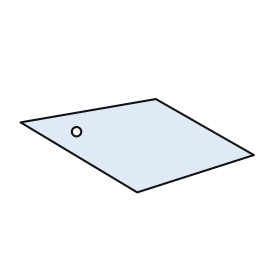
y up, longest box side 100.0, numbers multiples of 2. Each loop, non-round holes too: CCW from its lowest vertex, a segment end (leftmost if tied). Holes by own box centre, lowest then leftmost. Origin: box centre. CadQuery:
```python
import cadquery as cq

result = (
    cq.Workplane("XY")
    .moveTo(0.0, -20.0)
    .lineTo(50.0, -4.0)
    .lineTo(8.0, 20.0)
    .lineTo(-50.0, 10.0)
    .close()
    .moveTo(-26.0, 6.0)
    .circle(2.0)
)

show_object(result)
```